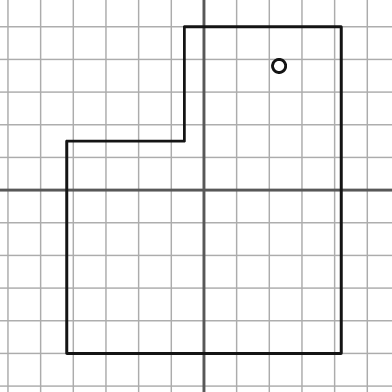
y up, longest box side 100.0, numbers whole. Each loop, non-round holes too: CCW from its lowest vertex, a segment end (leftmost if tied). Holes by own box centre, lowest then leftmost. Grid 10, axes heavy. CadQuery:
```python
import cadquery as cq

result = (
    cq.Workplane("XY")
    .moveTo(-42.0, -50.0)
    .lineTo(42.0, -50.0)
    .lineTo(42.0, 50.0)
    .lineTo(-6.0, 50.0)
    .lineTo(-6.0, 15.0)
    .lineTo(-42.0, 15.0)
    .close()
    .moveTo(23.0, 38.0)
    .circle(2.0)
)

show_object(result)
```